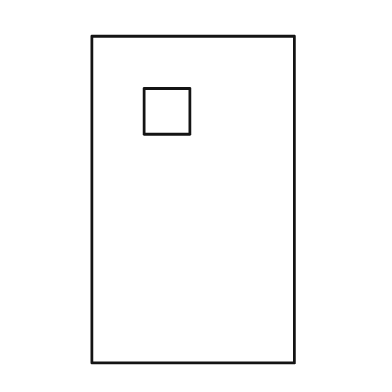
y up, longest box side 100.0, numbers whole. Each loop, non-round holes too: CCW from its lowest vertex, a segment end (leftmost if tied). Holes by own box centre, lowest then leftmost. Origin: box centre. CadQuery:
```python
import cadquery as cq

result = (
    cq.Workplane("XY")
    .moveTo(-31.0, -50.0)
    .lineTo(31.0, -50.0)
    .lineTo(31.0, 50.0)
    .lineTo(-31.0, 50.0)
    .close()
    .moveTo(-15.0, 20.0)
    .lineTo(-1.0, 20.0)
    .lineTo(-1.0, 34.0)
    .lineTo(-15.0, 34.0)
    .close()
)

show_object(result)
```